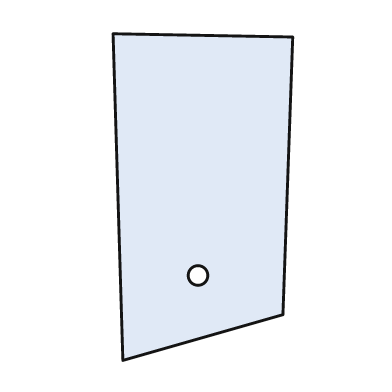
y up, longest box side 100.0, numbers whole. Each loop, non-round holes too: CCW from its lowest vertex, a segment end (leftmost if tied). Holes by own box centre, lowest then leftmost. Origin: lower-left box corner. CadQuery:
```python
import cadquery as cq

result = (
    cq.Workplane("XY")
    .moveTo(3.0, 0.0)
    .lineTo(52.0, 14.0)
    .lineTo(55.0, 99.0)
    .lineTo(0.0, 100.0)
    .close()
    .moveTo(26.0, 26.0)
    .circle(3.0)
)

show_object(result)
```